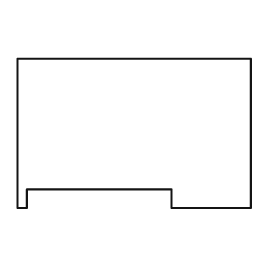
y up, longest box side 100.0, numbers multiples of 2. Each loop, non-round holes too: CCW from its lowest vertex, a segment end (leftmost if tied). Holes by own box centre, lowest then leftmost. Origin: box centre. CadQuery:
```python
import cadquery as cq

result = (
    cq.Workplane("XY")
    .moveTo(-50.0, -32.0)
    .lineTo(-46.0, -32.0)
    .lineTo(-46.0, -24.0)
    .lineTo(16.0, -24.0)
    .lineTo(16.0, -32.0)
    .lineTo(50.0, -32.0)
    .lineTo(50.0, 32.0)
    .lineTo(-50.0, 32.0)
    .close()
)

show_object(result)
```